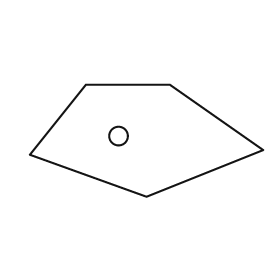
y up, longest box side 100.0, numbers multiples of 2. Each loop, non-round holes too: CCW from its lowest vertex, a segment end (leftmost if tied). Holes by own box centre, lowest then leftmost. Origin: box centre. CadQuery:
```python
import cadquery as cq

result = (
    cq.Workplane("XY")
    .moveTo(0.0, -24.0)
    .lineTo(50.0, -4.0)
    .lineTo(10.0, 24.0)
    .lineTo(-26.0, 24.0)
    .lineTo(-50.0, -6.0)
    .close()
    .moveTo(-12.0, 2.0)
    .circle(4.0)
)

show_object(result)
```